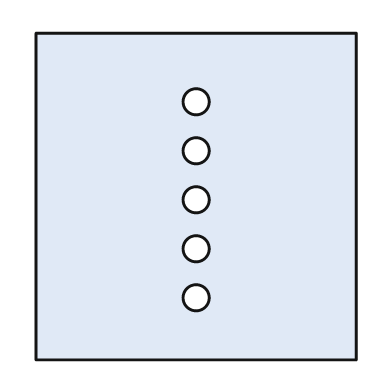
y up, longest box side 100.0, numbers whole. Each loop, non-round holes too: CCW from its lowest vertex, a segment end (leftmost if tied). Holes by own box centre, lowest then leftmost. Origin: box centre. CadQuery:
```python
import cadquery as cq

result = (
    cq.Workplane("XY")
    .moveTo(-49.0, -50.0)
    .lineTo(49.0, -50.0)
    .lineTo(49.0, 50.0)
    .lineTo(-49.0, 50.0)
    .close()
    .moveTo(0.0, -31.0)
    .circle(4.0)
    .moveTo(0.0, -16.0)
    .circle(4.0)
    .moveTo(0.0, -1.0)
    .circle(4.0)
    .moveTo(0.0, 14.0)
    .circle(4.0)
    .moveTo(0.0, 29.0)
    .circle(4.0)
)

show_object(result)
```